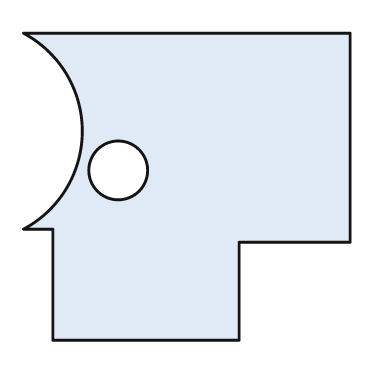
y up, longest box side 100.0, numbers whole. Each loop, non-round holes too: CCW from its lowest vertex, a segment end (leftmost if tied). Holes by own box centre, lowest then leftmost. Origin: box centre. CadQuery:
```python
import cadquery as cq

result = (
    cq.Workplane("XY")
    .moveTo(-41.0, -47.0)
    .lineTo(16.0, -47.0)
    .lineTo(16.0, -17.0)
    .lineTo(50.0, -17.0)
    .lineTo(50.0, 47.0)
    .lineTo(-50.0, 47.0)
    .threePointArc((-32.0, 17.0), (-50.0, -13.0))
    .lineTo(-41.0, -13.0)
    .close()
    .moveTo(-21.0, 5.0)
    .circle(9.0)
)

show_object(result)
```